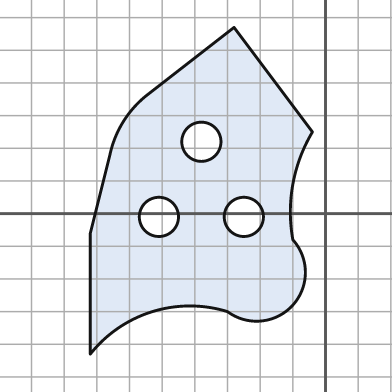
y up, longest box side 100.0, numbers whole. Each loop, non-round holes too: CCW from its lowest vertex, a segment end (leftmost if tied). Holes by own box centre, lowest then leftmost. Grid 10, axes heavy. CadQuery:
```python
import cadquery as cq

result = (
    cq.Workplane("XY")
    .moveTo(-72.0, -43.0)
    .threePointArc((-53.0, -30.0), (-30.0, -30.0))
    .threePointArc((-10.0, -28.0), (-10.0, -8.0))
    .threePointArc((-10.0, 9.0), (-4.0, 25.0))
    .lineTo(-28.0, 57.0)
    .lineTo(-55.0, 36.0)
    .threePointArc((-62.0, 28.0), (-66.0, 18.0))
    .lineTo(-72.0, -6.0)
    .close()
    .moveTo(-51.0, -1.0)
    .circle(6.0)
    .moveTo(-25.0, -1.0)
    .circle(6.0)
    .moveTo(-38.0, 22.0)
    .circle(6.0)
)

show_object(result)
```